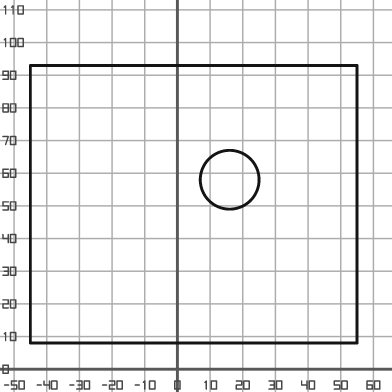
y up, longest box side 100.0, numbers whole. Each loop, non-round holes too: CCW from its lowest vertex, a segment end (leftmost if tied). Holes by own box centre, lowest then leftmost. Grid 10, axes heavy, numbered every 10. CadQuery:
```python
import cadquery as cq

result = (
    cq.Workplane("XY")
    .moveTo(-45.0, 8.0)
    .lineTo(55.0, 8.0)
    .lineTo(55.0, 93.0)
    .lineTo(-45.0, 93.0)
    .close()
    .moveTo(16.0, 58.0)
    .circle(9.0)
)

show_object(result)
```